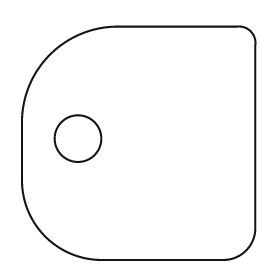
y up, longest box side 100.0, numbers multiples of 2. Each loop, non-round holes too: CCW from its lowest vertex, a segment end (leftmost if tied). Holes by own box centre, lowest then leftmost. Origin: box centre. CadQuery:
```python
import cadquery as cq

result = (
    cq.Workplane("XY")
    .moveTo(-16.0, -50.0)
    .lineTo(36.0, -50.0)
    .threePointArc((46.0, -46.0), (50.0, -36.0))
    .lineTo(50.0, 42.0)
    .threePointArc((48.0, 48.0), (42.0, 50.0))
    .lineTo(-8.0, 50.0)
    .threePointArc((-38.0, 38.0), (-50.0, 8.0))
    .lineTo(-50.0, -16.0)
    .threePointArc((-40.0, -40.0), (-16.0, -50.0))
    .close()
    .moveTo(-26.0, 2.0)
    .circle(10.0)
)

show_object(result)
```